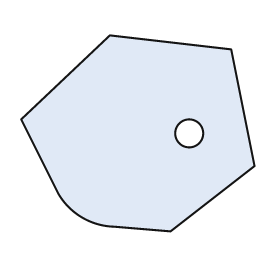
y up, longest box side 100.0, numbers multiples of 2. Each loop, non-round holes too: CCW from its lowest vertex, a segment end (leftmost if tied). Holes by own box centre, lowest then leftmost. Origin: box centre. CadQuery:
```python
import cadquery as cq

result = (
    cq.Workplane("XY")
    .moveTo(14.0, -42.0)
    .lineTo(50.0, -14.0)
    .lineTo(40.0, 36.0)
    .lineTo(-12.0, 42.0)
    .lineTo(-50.0, 6.0)
    .lineTo(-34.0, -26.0)
    .threePointArc((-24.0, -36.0), (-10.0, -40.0))
    .close()
    .moveTo(22.0, 0.0)
    .circle(6.0)
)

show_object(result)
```